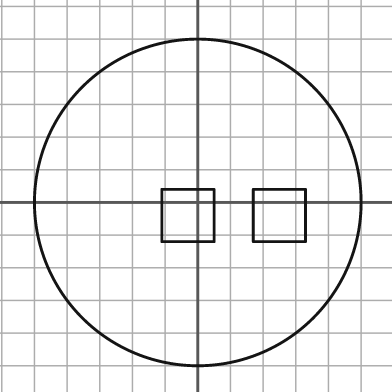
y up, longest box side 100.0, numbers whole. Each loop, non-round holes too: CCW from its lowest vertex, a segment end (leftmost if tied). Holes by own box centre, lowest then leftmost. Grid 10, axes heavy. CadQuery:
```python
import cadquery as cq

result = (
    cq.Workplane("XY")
    .moveTo(0.0, 0.0)
    .circle(50.0)
    .moveTo(-11.0, -12.0)
    .lineTo(5.0, -12.0)
    .lineTo(5.0, 4.0)
    .lineTo(-11.0, 4.0)
    .close()
    .moveTo(17.0, -12.0)
    .lineTo(33.0, -12.0)
    .lineTo(33.0, 4.0)
    .lineTo(17.0, 4.0)
    .close()
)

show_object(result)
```